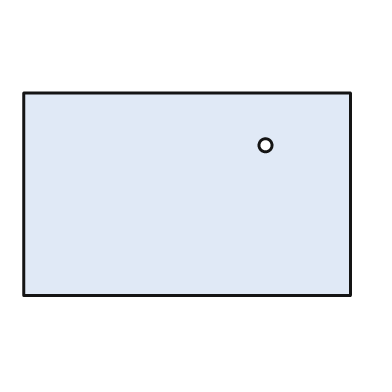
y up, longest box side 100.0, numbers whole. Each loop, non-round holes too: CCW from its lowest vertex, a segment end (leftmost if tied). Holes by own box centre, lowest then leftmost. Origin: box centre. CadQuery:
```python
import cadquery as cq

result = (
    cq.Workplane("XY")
    .moveTo(-50.0, -31.0)
    .lineTo(50.0, -31.0)
    .lineTo(50.0, 31.0)
    .lineTo(-50.0, 31.0)
    .close()
    .moveTo(24.0, 15.0)
    .circle(2.0)
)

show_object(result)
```